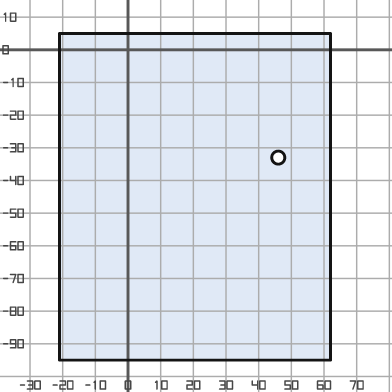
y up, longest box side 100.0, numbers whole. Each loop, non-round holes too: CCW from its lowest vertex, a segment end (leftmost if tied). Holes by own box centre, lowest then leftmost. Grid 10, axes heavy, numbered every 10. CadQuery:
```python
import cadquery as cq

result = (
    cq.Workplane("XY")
    .moveTo(-21.0, -95.0)
    .lineTo(62.0, -95.0)
    .lineTo(62.0, 5.0)
    .lineTo(-21.0, 5.0)
    .close()
    .moveTo(46.0, -33.0)
    .circle(2.0)
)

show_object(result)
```